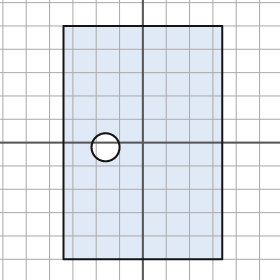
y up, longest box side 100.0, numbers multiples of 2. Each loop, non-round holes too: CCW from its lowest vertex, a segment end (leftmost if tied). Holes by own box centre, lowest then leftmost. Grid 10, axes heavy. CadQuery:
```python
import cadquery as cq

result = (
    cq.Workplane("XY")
    .moveTo(-34.0, -50.0)
    .lineTo(34.0, -50.0)
    .lineTo(34.0, 50.0)
    .lineTo(-34.0, 50.0)
    .close()
    .moveTo(-16.0, -2.0)
    .circle(6.0)
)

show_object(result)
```